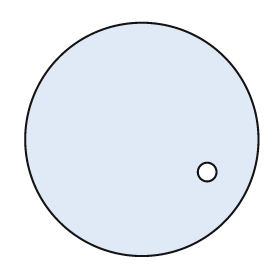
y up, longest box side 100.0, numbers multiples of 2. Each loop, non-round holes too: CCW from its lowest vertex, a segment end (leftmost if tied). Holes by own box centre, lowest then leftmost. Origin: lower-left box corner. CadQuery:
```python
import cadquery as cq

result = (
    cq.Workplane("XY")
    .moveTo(50.0, 50.0)
    .circle(50.0)
    .moveTo(78.0, 36.0)
    .circle(4.0)
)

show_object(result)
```